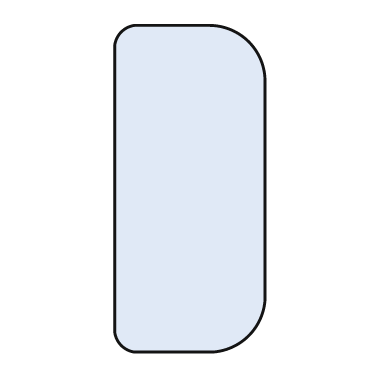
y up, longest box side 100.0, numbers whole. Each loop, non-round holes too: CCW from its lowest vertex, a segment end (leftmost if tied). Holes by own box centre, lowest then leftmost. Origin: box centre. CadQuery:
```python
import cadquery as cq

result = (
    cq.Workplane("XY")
    .moveTo(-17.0, -50.0)
    .lineTo(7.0, -50.0)
    .threePointArc((18.0, -45.0), (23.0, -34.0))
    .lineTo(23.0, 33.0)
    .threePointArc((18.0, 45.0), (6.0, 50.0))
    .lineTo(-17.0, 50.0)
    .threePointArc((-21.0, 48.0), (-23.0, 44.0))
    .lineTo(-23.0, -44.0)
    .threePointArc((-21.0, -48.0), (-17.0, -50.0))
    .close()
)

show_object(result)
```